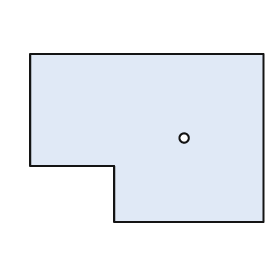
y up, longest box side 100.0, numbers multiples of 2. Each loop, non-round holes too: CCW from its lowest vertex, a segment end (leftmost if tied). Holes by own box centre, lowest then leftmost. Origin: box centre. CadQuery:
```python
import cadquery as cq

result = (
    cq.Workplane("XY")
    .moveTo(-14.0, -36.0)
    .lineTo(50.0, -36.0)
    .lineTo(50.0, 36.0)
    .lineTo(-50.0, 36.0)
    .lineTo(-50.0, -12.0)
    .lineTo(-14.0, -12.0)
    .close()
    .moveTo(16.0, 0.0)
    .circle(2.0)
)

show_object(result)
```